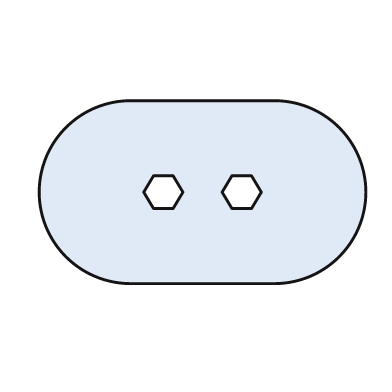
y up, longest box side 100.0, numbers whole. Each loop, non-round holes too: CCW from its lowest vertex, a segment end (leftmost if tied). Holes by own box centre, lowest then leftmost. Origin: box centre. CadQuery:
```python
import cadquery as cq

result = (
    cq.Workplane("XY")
    .moveTo(-22.0, -28.0)
    .lineTo(22.0, -28.0)
    .threePointArc((50.0, 0.0), (22.0, 28.0))
    .lineTo(-22.0, 28.0)
    .threePointArc((-50.0, 0.0), (-22.0, -28.0))
    .close()
    .moveTo(-15.0, -5.0)
    .lineTo(-9.0, -5.0)
    .lineTo(-6.0, 0.0)
    .lineTo(-9.0, 5.0)
    .lineTo(-15.0, 5.0)
    .lineTo(-18.0, 0.0)
    .close()
    .moveTo(9.0, -5.0)
    .lineTo(15.0, -5.0)
    .lineTo(18.0, 0.0)
    .lineTo(15.0, 5.0)
    .lineTo(9.0, 5.0)
    .lineTo(6.0, 0.0)
    .close()
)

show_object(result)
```